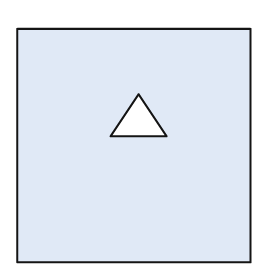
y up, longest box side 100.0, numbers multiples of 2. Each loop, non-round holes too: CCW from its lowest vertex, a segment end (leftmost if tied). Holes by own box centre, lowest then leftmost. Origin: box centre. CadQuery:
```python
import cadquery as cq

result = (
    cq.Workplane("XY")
    .moveTo(-50.0, -50.0)
    .lineTo(50.0, -50.0)
    .lineTo(50.0, 50.0)
    .lineTo(-50.0, 50.0)
    .close()
    .moveTo(-10.0, 4.0)
    .lineTo(14.0, 4.0)
    .lineTo(2.0, 22.0)
    .close()
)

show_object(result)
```